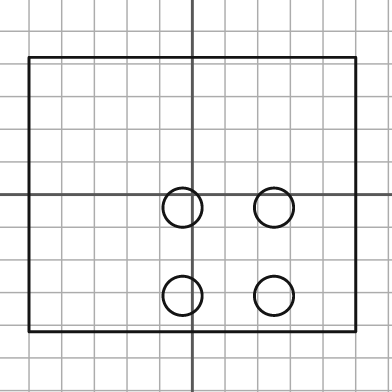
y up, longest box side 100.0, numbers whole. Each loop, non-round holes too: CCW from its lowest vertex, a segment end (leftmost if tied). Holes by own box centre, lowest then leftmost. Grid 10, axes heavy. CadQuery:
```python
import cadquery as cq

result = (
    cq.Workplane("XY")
    .moveTo(-50.0, -42.0)
    .lineTo(50.0, -42.0)
    .lineTo(50.0, 42.0)
    .lineTo(-50.0, 42.0)
    .close()
    .moveTo(-3.0, -31.0)
    .circle(6.0)
    .moveTo(25.0, -31.0)
    .circle(6.0)
    .moveTo(-3.0, -4.0)
    .circle(6.0)
    .moveTo(25.0, -4.0)
    .circle(6.0)
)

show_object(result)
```